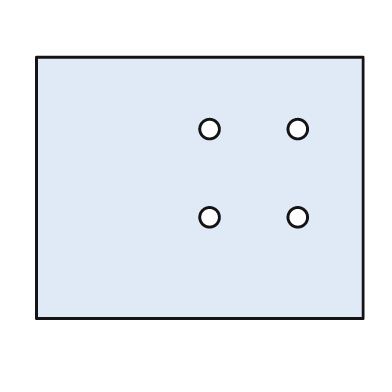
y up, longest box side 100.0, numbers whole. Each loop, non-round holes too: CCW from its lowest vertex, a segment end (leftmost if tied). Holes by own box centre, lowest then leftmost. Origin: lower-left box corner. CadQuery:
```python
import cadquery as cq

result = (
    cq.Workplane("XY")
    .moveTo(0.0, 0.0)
    .lineTo(100.0, 0.0)
    .lineTo(100.0, 80.0)
    .lineTo(0.0, 80.0)
    .close()
    .moveTo(53.0, 31.0)
    .circle(3.0)
    .moveTo(80.0, 31.0)
    .circle(3.0)
    .moveTo(53.0, 58.0)
    .circle(3.0)
    .moveTo(80.0, 58.0)
    .circle(3.0)
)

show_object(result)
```